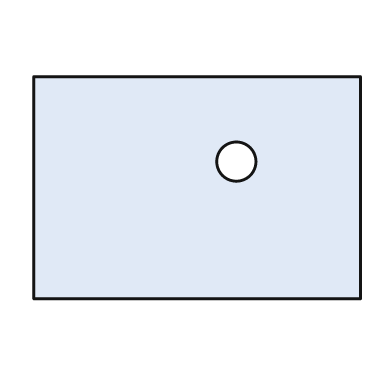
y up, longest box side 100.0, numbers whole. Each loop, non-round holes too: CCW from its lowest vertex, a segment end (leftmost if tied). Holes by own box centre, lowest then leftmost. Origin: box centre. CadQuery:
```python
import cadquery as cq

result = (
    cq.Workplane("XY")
    .moveTo(-50.0, -34.0)
    .lineTo(50.0, -34.0)
    .lineTo(50.0, 34.0)
    .lineTo(-50.0, 34.0)
    .close()
    .moveTo(12.0, 8.0)
    .circle(6.0)
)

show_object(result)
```